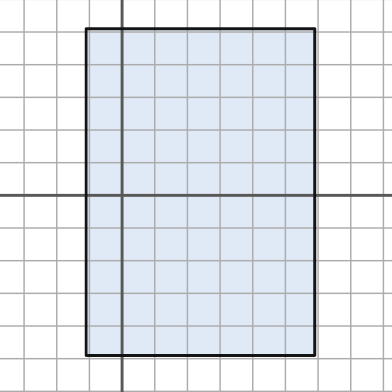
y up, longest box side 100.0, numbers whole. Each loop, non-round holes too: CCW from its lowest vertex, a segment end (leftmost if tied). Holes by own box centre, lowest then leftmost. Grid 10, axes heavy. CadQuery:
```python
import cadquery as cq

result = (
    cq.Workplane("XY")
    .moveTo(-11.0, -49.0)
    .lineTo(59.0, -49.0)
    .lineTo(59.0, 51.0)
    .lineTo(-11.0, 51.0)
    .close()
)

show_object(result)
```